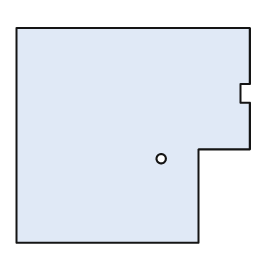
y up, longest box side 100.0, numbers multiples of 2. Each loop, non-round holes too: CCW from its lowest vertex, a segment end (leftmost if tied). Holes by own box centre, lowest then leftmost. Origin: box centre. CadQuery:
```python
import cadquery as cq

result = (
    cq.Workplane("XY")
    .moveTo(-50.0, -46.0)
    .lineTo(28.0, -46.0)
    .lineTo(28.0, -6.0)
    .lineTo(50.0, -6.0)
    .lineTo(50.0, 14.0)
    .lineTo(46.0, 14.0)
    .lineTo(46.0, 22.0)
    .lineTo(50.0, 22.0)
    .lineTo(50.0, 46.0)
    .lineTo(-50.0, 46.0)
    .close()
    .moveTo(12.0, -10.0)
    .circle(2.0)
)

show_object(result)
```